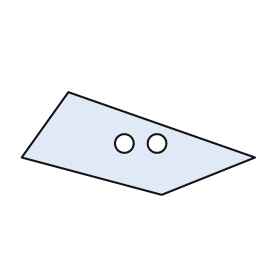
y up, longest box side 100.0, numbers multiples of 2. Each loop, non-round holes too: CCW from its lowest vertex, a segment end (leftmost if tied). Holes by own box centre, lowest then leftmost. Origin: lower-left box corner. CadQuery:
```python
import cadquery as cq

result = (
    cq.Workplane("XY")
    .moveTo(60.0, 0.0)
    .lineTo(100.0, 16.0)
    .lineTo(20.0, 44.0)
    .lineTo(0.0, 16.0)
    .close()
    .moveTo(44.0, 22.0)
    .circle(4.0)
    .moveTo(58.0, 22.0)
    .circle(4.0)
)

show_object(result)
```